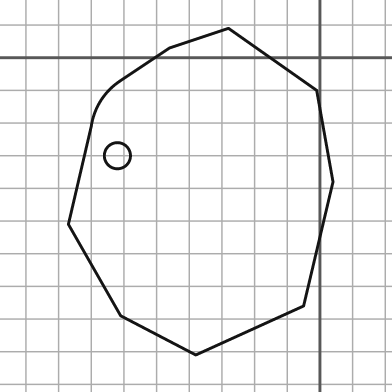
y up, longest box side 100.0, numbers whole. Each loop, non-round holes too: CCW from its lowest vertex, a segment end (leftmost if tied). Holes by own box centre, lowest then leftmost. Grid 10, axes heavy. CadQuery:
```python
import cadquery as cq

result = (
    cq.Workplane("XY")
    .moveTo(-38.0, -91.0)
    .lineTo(-5.0, -76.0)
    .lineTo(4.0, -38.0)
    .lineTo(-1.0, -10.0)
    .lineTo(-28.0, 9.0)
    .lineTo(-46.0, 3.0)
    .lineTo(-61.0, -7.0)
    .threePointArc((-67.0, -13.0), (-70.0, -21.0))
    .lineTo(-77.0, -51.0)
    .lineTo(-61.0, -79.0)
    .close()
    .moveTo(-62.0, -30.0)
    .circle(4.0)
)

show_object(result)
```